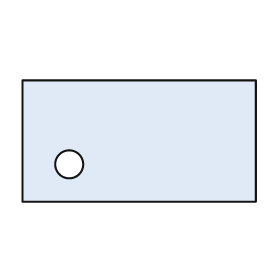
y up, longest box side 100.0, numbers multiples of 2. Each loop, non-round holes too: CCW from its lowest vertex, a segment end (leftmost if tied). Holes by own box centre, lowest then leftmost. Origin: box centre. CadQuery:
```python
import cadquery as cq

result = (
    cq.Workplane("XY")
    .moveTo(-50.0, -26.0)
    .lineTo(50.0, -26.0)
    .lineTo(50.0, 26.0)
    .lineTo(-50.0, 26.0)
    .close()
    .moveTo(-30.0, -10.0)
    .circle(6.0)
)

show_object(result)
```